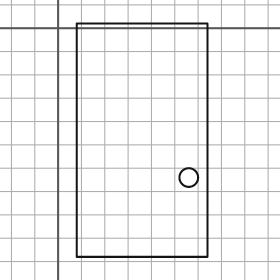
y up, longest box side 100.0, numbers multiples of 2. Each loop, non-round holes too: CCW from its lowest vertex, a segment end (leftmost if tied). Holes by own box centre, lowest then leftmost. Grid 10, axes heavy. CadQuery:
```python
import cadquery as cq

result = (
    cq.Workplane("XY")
    .moveTo(8.0, -98.0)
    .lineTo(64.0, -98.0)
    .lineTo(64.0, 2.0)
    .lineTo(8.0, 2.0)
    .close()
    .moveTo(56.0, -64.0)
    .circle(4.0)
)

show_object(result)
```